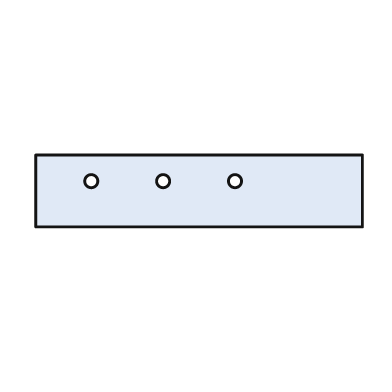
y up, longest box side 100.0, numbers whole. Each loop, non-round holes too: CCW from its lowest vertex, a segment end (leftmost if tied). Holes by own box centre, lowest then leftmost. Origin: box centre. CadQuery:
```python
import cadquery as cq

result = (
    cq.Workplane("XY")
    .moveTo(-50.0, -11.0)
    .lineTo(50.0, -11.0)
    .lineTo(50.0, 11.0)
    .lineTo(-50.0, 11.0)
    .close()
    .moveTo(-33.0, 3.0)
    .circle(2.0)
    .moveTo(-11.0, 3.0)
    .circle(2.0)
    .moveTo(11.0, 3.0)
    .circle(2.0)
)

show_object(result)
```